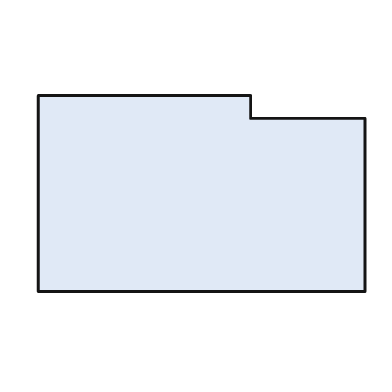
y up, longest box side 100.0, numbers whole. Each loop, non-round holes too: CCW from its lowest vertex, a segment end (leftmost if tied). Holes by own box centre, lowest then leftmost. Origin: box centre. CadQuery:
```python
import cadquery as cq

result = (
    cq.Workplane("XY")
    .moveTo(-50.0, -30.0)
    .lineTo(50.0, -30.0)
    .lineTo(50.0, 23.0)
    .lineTo(15.0, 23.0)
    .lineTo(15.0, 30.0)
    .lineTo(-50.0, 30.0)
    .close()
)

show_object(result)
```